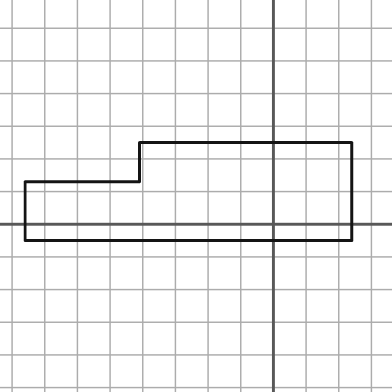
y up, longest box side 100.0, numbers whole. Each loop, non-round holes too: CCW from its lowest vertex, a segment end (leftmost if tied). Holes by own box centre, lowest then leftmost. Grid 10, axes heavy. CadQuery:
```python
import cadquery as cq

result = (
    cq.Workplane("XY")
    .moveTo(-76.0, -5.0)
    .lineTo(24.0, -5.0)
    .lineTo(24.0, 25.0)
    .lineTo(-41.0, 25.0)
    .lineTo(-41.0, 13.0)
    .lineTo(-76.0, 13.0)
    .close()
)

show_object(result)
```